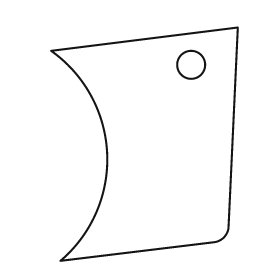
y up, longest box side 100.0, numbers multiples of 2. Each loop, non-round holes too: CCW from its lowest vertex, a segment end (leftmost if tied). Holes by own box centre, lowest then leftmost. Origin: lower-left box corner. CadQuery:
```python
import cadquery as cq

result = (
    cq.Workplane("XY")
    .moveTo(4.0, 0.0)
    .lineTo(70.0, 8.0)
    .threePointArc((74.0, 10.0), (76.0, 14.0))
    .lineTo(80.0, 100.0)
    .lineTo(0.0, 90.0)
    .threePointArc((24.0, 46.0), (4.0, 0.0))
    .close()
    .moveTo(60.0, 84.0)
    .circle(6.0)
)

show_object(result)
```